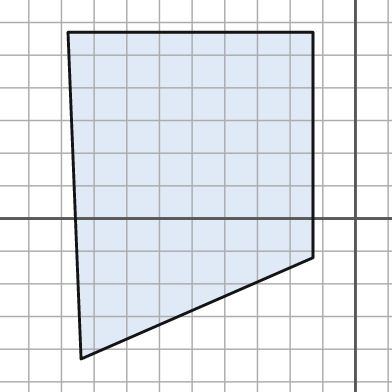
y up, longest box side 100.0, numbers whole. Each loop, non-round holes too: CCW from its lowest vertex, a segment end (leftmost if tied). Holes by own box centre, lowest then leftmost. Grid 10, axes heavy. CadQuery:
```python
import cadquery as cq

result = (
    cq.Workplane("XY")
    .moveTo(-84.0, -43.0)
    .lineTo(-13.0, -12.0)
    .lineTo(-13.0, 57.0)
    .lineTo(-88.0, 57.0)
    .close()
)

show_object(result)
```